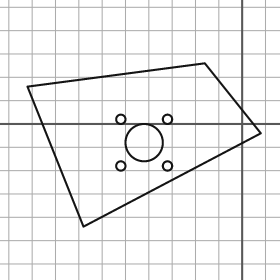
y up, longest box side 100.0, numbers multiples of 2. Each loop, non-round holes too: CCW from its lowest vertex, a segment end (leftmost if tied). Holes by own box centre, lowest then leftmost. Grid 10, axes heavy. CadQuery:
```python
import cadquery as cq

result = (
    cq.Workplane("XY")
    .moveTo(-68.0, -44.0)
    .lineTo(8.0, -4.0)
    .lineTo(-16.0, 26.0)
    .lineTo(-92.0, 16.0)
    .close()
    .moveTo(-52.0, -18.0)
    .circle(2.0)
    .moveTo(-32.0, -18.0)
    .circle(2.0)
    .moveTo(-42.0, -8.0)
    .circle(8.0)
    .moveTo(-52.0, 2.0)
    .circle(2.0)
    .moveTo(-32.0, 2.0)
    .circle(2.0)
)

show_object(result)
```